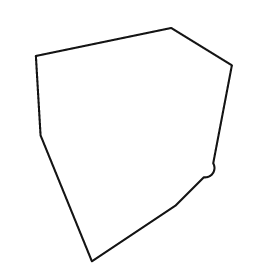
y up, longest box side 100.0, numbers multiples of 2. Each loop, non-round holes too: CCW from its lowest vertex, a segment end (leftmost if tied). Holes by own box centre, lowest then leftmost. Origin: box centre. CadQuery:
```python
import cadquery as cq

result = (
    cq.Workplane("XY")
    .moveTo(-18.0, -50.0)
    .lineTo(18.0, -26.0)
    .lineTo(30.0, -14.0)
    .threePointArc((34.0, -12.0), (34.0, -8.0))
    .lineTo(42.0, 34.0)
    .lineTo(16.0, 50.0)
    .lineTo(-42.0, 38.0)
    .lineTo(-40.0, 4.0)
    .close()
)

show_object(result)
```